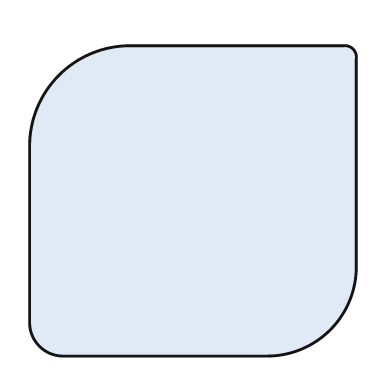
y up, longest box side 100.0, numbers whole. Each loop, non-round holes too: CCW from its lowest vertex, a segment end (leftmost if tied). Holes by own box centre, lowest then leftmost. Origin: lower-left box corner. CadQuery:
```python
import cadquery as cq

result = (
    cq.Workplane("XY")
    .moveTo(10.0, 0.0)
    .lineTo(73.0, 0.0)
    .threePointArc((92.0, 8.0), (100.0, 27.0))
    .lineTo(100.0, 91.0)
    .threePointArc((99.0, 94.0), (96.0, 95.0))
    .lineTo(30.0, 95.0)
    .threePointArc((9.0, 86.0), (0.0, 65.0))
    .lineTo(0.0, 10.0)
    .threePointArc((3.0, 3.0), (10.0, 0.0))
    .close()
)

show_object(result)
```